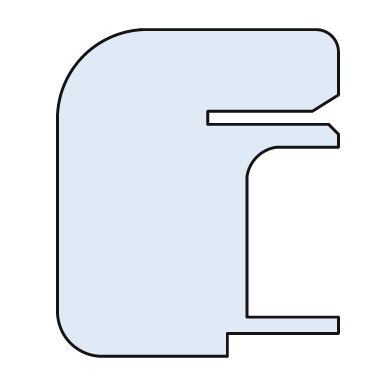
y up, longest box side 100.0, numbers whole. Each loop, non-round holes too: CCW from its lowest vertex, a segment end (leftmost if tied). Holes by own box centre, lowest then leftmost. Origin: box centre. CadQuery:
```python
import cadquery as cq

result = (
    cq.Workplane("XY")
    .moveTo(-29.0, -50.0)
    .lineTo(9.0, -50.0)
    .lineTo(9.0, -43.0)
    .lineTo(43.0, -43.0)
    .lineTo(43.0, -38.0)
    .lineTo(15.0, -38.0)
    .lineTo(15.0, 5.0)
    .threePointArc((18.0, 11.0), (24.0, 14.0))
    .lineTo(43.0, 14.0)
    .lineTo(43.0, 18.0)
    .lineTo(40.0, 21.0)
    .lineTo(3.0, 21.0)
    .lineTo(3.0, 25.0)
    .lineTo(35.0, 25.0)
    .lineTo(43.0, 30.0)
    .lineTo(43.0, 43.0)
    .threePointArc((41.0, 48.0), (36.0, 50.0))
    .lineTo(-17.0, 50.0)
    .threePointArc((-35.0, 42.0), (-43.0, 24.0))
    .lineTo(-43.0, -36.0)
    .threePointArc((-39.0, -46.0), (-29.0, -50.0))
    .close()
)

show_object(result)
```